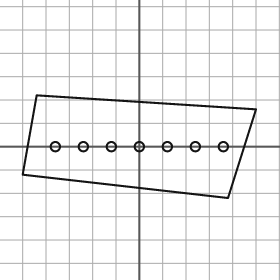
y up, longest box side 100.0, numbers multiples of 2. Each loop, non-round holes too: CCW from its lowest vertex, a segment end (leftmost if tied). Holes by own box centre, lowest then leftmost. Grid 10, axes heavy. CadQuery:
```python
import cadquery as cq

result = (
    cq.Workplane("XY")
    .moveTo(38.0, -22.0)
    .lineTo(50.0, 16.0)
    .lineTo(-44.0, 22.0)
    .lineTo(-50.0, -12.0)
    .close()
    .moveTo(-36.0, 0.0)
    .circle(2.0)
    .moveTo(-24.0, 0.0)
    .circle(2.0)
    .moveTo(-12.0, 0.0)
    .circle(2.0)
    .moveTo(0.0, 0.0)
    .circle(2.0)
    .moveTo(12.0, 0.0)
    .circle(2.0)
    .moveTo(24.0, 0.0)
    .circle(2.0)
    .moveTo(36.0, 0.0)
    .circle(2.0)
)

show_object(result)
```